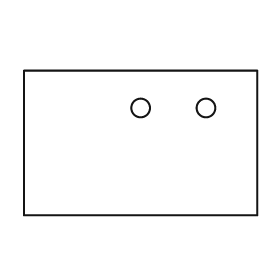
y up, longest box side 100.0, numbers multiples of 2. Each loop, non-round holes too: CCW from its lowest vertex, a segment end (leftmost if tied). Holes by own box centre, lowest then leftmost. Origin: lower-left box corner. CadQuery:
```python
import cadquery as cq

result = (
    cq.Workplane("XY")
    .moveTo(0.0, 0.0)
    .lineTo(100.0, 0.0)
    .lineTo(100.0, 62.0)
    .lineTo(0.0, 62.0)
    .close()
    .moveTo(50.0, 46.0)
    .circle(4.0)
    .moveTo(78.0, 46.0)
    .circle(4.0)
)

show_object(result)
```